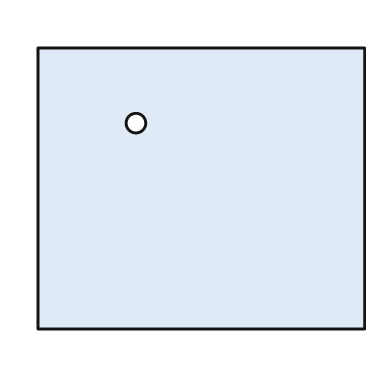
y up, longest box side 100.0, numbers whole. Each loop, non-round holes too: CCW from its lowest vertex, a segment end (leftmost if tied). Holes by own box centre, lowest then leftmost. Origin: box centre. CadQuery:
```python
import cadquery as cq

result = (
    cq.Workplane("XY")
    .moveTo(-50.0, -43.0)
    .lineTo(50.0, -43.0)
    .lineTo(50.0, 43.0)
    .lineTo(-50.0, 43.0)
    .close()
    .moveTo(-20.0, 20.0)
    .circle(3.0)
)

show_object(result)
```